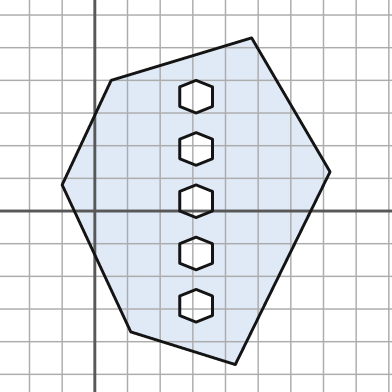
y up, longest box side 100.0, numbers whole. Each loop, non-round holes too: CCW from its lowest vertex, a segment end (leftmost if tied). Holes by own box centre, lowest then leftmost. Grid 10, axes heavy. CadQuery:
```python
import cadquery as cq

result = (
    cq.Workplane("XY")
    .moveTo(43.0, -47.0)
    .lineTo(72.0, 12.0)
    .lineTo(48.0, 53.0)
    .lineTo(5.0, 40.0)
    .lineTo(-10.0, 8.0)
    .lineTo(11.0, -37.0)
    .close()
    .moveTo(31.0, -34.0)
    .lineTo(36.0, -32.0)
    .lineTo(36.0, -26.0)
    .lineTo(31.0, -24.0)
    .lineTo(26.0, -26.0)
    .lineTo(26.0, -32.0)
    .close()
    .moveTo(31.0, -18.0)
    .lineTo(36.0, -16.0)
    .lineTo(36.0, -10.0)
    .lineTo(31.0, -8.0)
    .lineTo(26.0, -10.0)
    .lineTo(26.0, -16.0)
    .close()
    .moveTo(31.0, -2.0)
    .lineTo(36.0, 0.0)
    .lineTo(36.0, 6.0)
    .lineTo(31.0, 8.0)
    .lineTo(26.0, 6.0)
    .lineTo(26.0, 0.0)
    .close()
    .moveTo(31.0, 14.0)
    .lineTo(36.0, 16.0)
    .lineTo(36.0, 22.0)
    .lineTo(31.0, 24.0)
    .lineTo(26.0, 22.0)
    .lineTo(26.0, 16.0)
    .close()
    .moveTo(31.0, 30.0)
    .lineTo(36.0, 32.0)
    .lineTo(36.0, 38.0)
    .lineTo(31.0, 40.0)
    .lineTo(26.0, 38.0)
    .lineTo(26.0, 32.0)
    .close()
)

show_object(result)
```